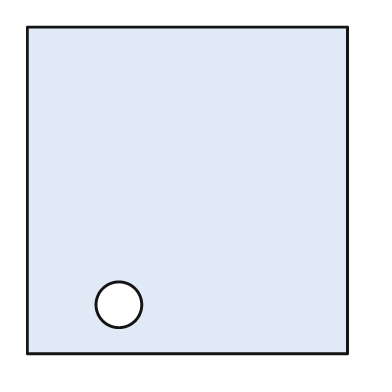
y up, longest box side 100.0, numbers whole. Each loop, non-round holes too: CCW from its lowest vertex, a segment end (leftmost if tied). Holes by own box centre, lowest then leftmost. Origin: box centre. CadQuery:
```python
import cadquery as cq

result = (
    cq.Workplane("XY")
    .moveTo(-49.0, -50.0)
    .lineTo(49.0, -50.0)
    .lineTo(49.0, 50.0)
    .lineTo(-49.0, 50.0)
    .close()
    .moveTo(-21.0, -35.0)
    .circle(7.0)
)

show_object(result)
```